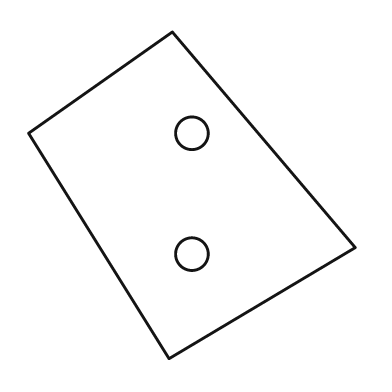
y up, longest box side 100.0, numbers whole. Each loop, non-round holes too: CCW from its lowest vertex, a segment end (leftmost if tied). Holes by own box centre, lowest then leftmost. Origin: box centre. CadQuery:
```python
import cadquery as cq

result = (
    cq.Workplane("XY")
    .moveTo(-7.0, -50.0)
    .lineTo(50.0, -16.0)
    .lineTo(-6.0, 50.0)
    .lineTo(-50.0, 19.0)
    .close()
    .moveTo(0.0, -18.0)
    .circle(5.0)
    .moveTo(0.0, 19.0)
    .circle(5.0)
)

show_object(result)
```